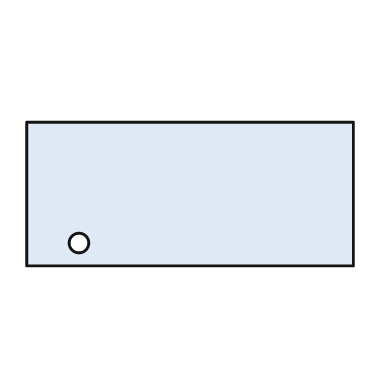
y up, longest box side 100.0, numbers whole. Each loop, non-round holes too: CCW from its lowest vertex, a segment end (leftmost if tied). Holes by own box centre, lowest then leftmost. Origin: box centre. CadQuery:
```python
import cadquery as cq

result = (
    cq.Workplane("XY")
    .moveTo(-50.0, -22.0)
    .lineTo(50.0, -22.0)
    .lineTo(50.0, 22.0)
    .lineTo(-50.0, 22.0)
    .close()
    .moveTo(-34.0, -15.0)
    .circle(3.0)
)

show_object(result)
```